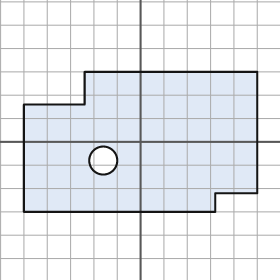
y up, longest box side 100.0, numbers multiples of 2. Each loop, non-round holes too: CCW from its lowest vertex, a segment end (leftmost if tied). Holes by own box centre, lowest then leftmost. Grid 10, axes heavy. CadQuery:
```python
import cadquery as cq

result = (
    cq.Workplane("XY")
    .moveTo(-50.0, -30.0)
    .lineTo(32.0, -30.0)
    .lineTo(32.0, -22.0)
    .lineTo(50.0, -22.0)
    .lineTo(50.0, 30.0)
    .lineTo(-24.0, 30.0)
    .lineTo(-24.0, 16.0)
    .lineTo(-50.0, 16.0)
    .close()
    .moveTo(-16.0, -8.0)
    .circle(6.0)
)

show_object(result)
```